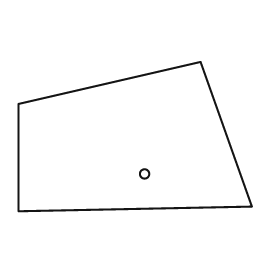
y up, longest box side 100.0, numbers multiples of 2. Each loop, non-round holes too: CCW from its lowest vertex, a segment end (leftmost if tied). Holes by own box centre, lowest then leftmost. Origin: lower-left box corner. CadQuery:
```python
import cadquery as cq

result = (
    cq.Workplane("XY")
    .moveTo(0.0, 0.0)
    .lineTo(100.0, 2.0)
    .lineTo(78.0, 64.0)
    .lineTo(0.0, 46.0)
    .close()
    .moveTo(54.0, 16.0)
    .circle(2.0)
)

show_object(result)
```